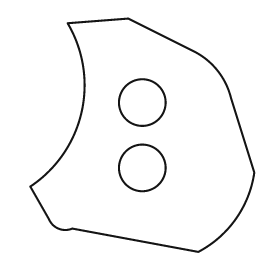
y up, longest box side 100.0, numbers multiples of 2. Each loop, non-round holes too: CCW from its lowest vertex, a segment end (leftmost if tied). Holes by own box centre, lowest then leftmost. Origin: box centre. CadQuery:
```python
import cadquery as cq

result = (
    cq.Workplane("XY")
    .moveTo(24.0, -50.0)
    .threePointArc((40.0, -36.0), (48.0, -16.0))
    .lineTo(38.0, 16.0)
    .threePointArc((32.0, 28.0), (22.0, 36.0))
    .lineTo(-6.0, 50.0)
    .lineTo(-32.0, 48.0)
    .threePointArc((-26.0, 10.0), (-48.0, -22.0))
    .lineTo(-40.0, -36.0)
    .threePointArc((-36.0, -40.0), (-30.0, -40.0))
    .close()
    .moveTo(0.0, -14.0)
    .circle(10.0)
    .moveTo(0.0, 14.0)
    .circle(10.0)
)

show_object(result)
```